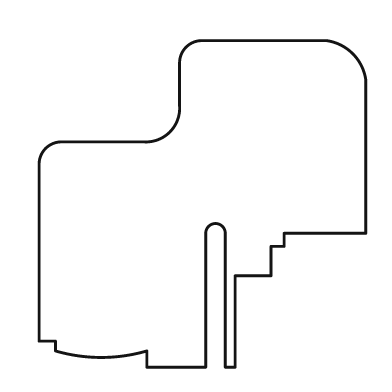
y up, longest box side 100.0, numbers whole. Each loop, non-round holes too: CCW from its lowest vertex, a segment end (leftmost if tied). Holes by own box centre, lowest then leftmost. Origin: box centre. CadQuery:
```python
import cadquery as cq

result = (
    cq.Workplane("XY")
    .moveTo(-17.0, -50.0)
    .lineTo(1.0, -50.0)
    .lineTo(1.0, -9.0)
    .threePointArc((4.0, -6.0), (7.0, -9.0))
    .lineTo(7.0, -50.0)
    .lineTo(10.0, -50.0)
    .lineTo(10.0, -22.0)
    .lineTo(21.0, -22.0)
    .lineTo(21.0, -13.0)
    .lineTo(25.0, -13.0)
    .lineTo(25.0, -9.0)
    .lineTo(50.0, -9.0)
    .lineTo(50.0, 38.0)
    .threePointArc((46.0, 46.0), (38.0, 50.0))
    .lineTo(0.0, 50.0)
    .threePointArc((-5.0, 48.0), (-7.0, 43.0))
    .lineTo(-7.0, 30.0)
    .threePointArc((-10.0, 22.0), (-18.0, 19.0))
    .lineTo(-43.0, 19.0)
    .threePointArc((-48.0, 17.0), (-50.0, 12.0))
    .lineTo(-50.0, -42.0)
    .lineTo(-45.0, -42.0)
    .lineTo(-45.0, -45.0)
    .threePointArc((-31.0, -47.0), (-17.0, -45.0))
    .close()
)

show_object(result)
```